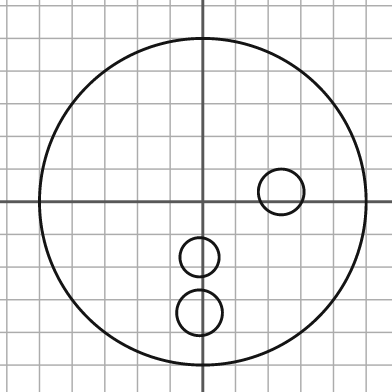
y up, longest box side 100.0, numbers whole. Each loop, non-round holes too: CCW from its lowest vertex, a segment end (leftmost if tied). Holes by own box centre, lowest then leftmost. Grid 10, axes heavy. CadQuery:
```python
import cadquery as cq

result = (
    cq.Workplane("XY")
    .moveTo(0.0, 0.0)
    .circle(50.0)
    .moveTo(-1.0, -34.0)
    .circle(7.0)
    .moveTo(-1.0, -17.0)
    .circle(6.0)
    .moveTo(24.0, 3.0)
    .circle(7.0)
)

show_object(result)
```